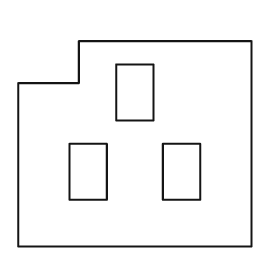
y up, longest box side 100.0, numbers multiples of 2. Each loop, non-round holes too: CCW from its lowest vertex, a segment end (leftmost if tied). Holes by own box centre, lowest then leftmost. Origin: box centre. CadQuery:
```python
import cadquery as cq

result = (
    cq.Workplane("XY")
    .moveTo(-50.0, -44.0)
    .lineTo(50.0, -44.0)
    .lineTo(50.0, 44.0)
    .lineTo(-24.0, 44.0)
    .lineTo(-24.0, 26.0)
    .lineTo(-50.0, 26.0)
    .close()
    .moveTo(-28.0, -24.0)
    .lineTo(-12.0, -24.0)
    .lineTo(-12.0, 0.0)
    .lineTo(-28.0, 0.0)
    .close()
    .moveTo(12.0, -24.0)
    .lineTo(28.0, -24.0)
    .lineTo(28.0, 0.0)
    .lineTo(12.0, 0.0)
    .close()
    .moveTo(-8.0, 10.0)
    .lineTo(8.0, 10.0)
    .lineTo(8.0, 34.0)
    .lineTo(-8.0, 34.0)
    .close()
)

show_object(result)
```